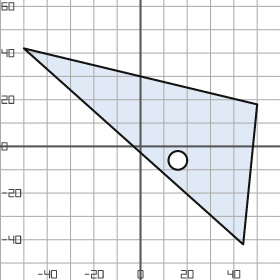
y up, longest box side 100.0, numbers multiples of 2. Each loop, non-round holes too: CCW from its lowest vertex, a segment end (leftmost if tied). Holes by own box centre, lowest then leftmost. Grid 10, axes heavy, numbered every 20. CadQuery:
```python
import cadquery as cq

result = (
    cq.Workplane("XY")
    .moveTo(44.0, -42.0)
    .lineTo(50.0, 18.0)
    .lineTo(-50.0, 42.0)
    .close()
    .moveTo(16.0, -6.0)
    .circle(4.0)
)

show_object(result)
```